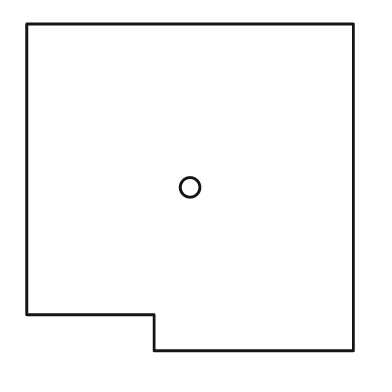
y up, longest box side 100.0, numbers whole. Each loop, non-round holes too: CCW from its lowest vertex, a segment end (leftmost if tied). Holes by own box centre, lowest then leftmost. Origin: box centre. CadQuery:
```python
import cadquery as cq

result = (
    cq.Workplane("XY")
    .moveTo(-11.0, -50.0)
    .lineTo(50.0, -50.0)
    .lineTo(50.0, 50.0)
    .lineTo(-50.0, 50.0)
    .lineTo(-50.0, -39.0)
    .lineTo(-11.0, -39.0)
    .close()
    .moveTo(0.0, 0.0)
    .circle(3.0)
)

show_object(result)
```